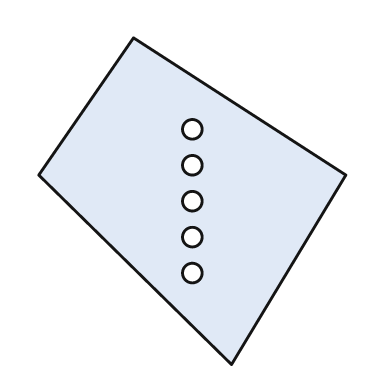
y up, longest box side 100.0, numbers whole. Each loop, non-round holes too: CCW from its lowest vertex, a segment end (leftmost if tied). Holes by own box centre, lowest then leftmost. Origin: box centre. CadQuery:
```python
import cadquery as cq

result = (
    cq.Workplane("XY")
    .moveTo(12.0, -50.0)
    .lineTo(47.0, 8.0)
    .lineTo(-18.0, 50.0)
    .lineTo(-47.0, 8.0)
    .close()
    .moveTo(0.0, -22.0)
    .circle(3.0)
    .moveTo(0.0, -11.0)
    .circle(3.0)
    .moveTo(0.0, 0.0)
    .circle(3.0)
    .moveTo(0.0, 11.0)
    .circle(3.0)
    .moveTo(0.0, 22.0)
    .circle(3.0)
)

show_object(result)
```